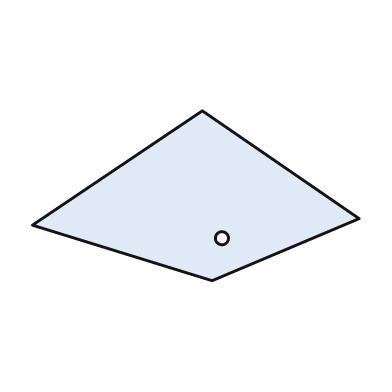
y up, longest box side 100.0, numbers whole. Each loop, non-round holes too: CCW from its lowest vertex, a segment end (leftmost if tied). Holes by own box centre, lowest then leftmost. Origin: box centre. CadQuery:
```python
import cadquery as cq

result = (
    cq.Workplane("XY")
    .moveTo(5.0, -26.0)
    .lineTo(50.0, -7.0)
    .lineTo(2.0, 26.0)
    .lineTo(-50.0, -9.0)
    .close()
    .moveTo(8.0, -13.0)
    .circle(2.0)
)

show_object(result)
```